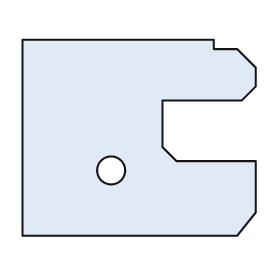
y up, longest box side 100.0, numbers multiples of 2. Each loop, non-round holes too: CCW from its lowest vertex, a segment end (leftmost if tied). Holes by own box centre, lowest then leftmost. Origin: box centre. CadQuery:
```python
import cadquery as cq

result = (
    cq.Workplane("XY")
    .moveTo(-50.0, -42.0)
    .lineTo(42.0, -42.0)
    .lineTo(50.0, -32.0)
    .lineTo(50.0, -10.0)
    .lineTo(16.0, -10.0)
    .lineTo(10.0, -4.0)
    .lineTo(10.0, 16.0)
    .lineTo(44.0, 16.0)
    .lineTo(50.0, 22.0)
    .lineTo(50.0, 30.0)
    .lineTo(42.0, 38.0)
    .lineTo(32.0, 38.0)
    .lineTo(32.0, 42.0)
    .lineTo(-50.0, 42.0)
    .close()
    .moveTo(-12.0, -14.0)
    .circle(6.0)
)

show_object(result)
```